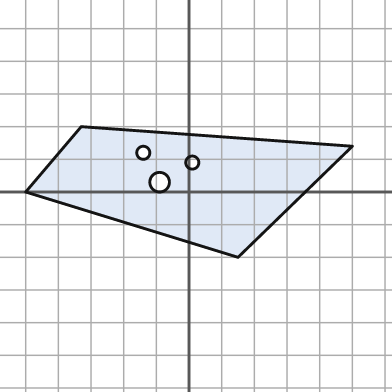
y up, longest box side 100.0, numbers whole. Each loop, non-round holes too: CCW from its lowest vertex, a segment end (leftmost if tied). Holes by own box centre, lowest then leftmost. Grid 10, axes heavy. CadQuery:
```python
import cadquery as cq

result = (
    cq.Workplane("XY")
    .moveTo(15.0, -20.0)
    .lineTo(50.0, 14.0)
    .lineTo(-33.0, 20.0)
    .lineTo(-50.0, 0.0)
    .close()
    .moveTo(-9.0, 3.0)
    .circle(3.0)
    .moveTo(1.0, 9.0)
    .circle(2.0)
    .moveTo(-14.0, 12.0)
    .circle(2.0)
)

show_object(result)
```